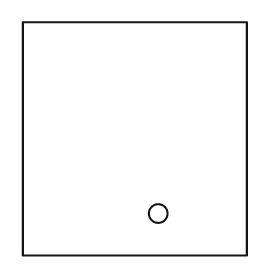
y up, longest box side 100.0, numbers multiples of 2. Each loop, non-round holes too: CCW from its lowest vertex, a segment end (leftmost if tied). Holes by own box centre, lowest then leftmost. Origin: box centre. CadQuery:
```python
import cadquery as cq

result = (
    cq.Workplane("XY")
    .moveTo(-48.0, -50.0)
    .lineTo(48.0, -50.0)
    .lineTo(48.0, 50.0)
    .lineTo(-48.0, 50.0)
    .close()
    .moveTo(10.0, -32.0)
    .circle(4.0)
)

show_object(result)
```